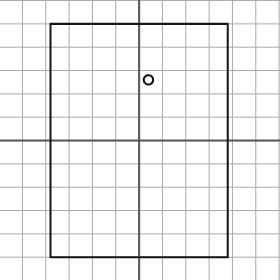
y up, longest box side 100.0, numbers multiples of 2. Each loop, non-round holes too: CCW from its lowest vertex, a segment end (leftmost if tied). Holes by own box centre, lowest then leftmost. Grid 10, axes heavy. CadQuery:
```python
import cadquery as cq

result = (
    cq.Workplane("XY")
    .moveTo(-38.0, -50.0)
    .lineTo(38.0, -50.0)
    .lineTo(38.0, 50.0)
    .lineTo(-38.0, 50.0)
    .close()
    .moveTo(4.0, 26.0)
    .circle(2.0)
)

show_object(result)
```